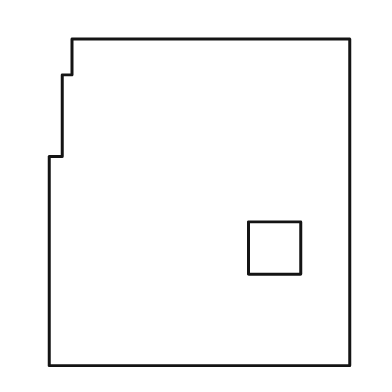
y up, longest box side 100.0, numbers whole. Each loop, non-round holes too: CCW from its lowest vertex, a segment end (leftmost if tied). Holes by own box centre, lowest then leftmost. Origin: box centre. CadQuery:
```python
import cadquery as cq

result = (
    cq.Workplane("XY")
    .moveTo(-46.0, -50.0)
    .lineTo(46.0, -50.0)
    .lineTo(46.0, 50.0)
    .lineTo(-39.0, 50.0)
    .lineTo(-39.0, 39.0)
    .lineTo(-42.0, 39.0)
    .lineTo(-42.0, 14.0)
    .lineTo(-46.0, 14.0)
    .close()
    .moveTo(15.0, -22.0)
    .lineTo(31.0, -22.0)
    .lineTo(31.0, -6.0)
    .lineTo(15.0, -6.0)
    .close()
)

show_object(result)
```